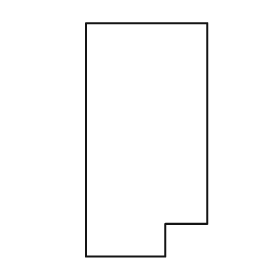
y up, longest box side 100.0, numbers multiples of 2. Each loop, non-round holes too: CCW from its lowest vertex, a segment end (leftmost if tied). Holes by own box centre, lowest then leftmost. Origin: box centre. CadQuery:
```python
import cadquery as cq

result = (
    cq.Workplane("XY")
    .moveTo(-26.0, -50.0)
    .lineTo(8.0, -50.0)
    .lineTo(8.0, -36.0)
    .lineTo(26.0, -36.0)
    .lineTo(26.0, 50.0)
    .lineTo(-26.0, 50.0)
    .close()
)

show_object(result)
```